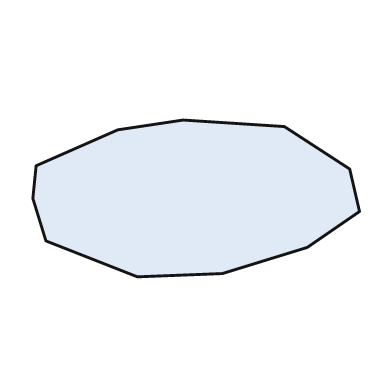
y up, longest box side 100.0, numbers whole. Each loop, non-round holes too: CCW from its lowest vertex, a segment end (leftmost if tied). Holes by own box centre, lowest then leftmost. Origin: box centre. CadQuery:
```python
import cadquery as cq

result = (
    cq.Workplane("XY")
    .moveTo(-18.0, -24.0)
    .lineTo(8.0, -23.0)
    .lineTo(34.0, -15.0)
    .lineTo(50.0, -4.0)
    .lineTo(47.0, 9.0)
    .lineTo(27.0, 22.0)
    .lineTo(-4.0, 24.0)
    .lineTo(-24.0, 21.0)
    .lineTo(-49.0, 10.0)
    .lineTo(-50.0, 0.0)
    .lineTo(-46.0, -13.0)
    .close()
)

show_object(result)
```